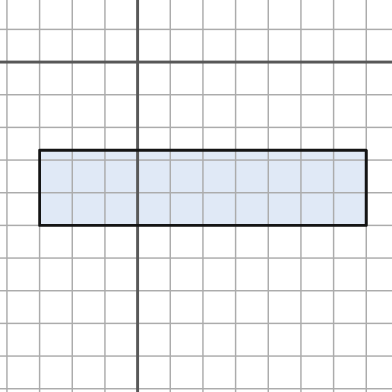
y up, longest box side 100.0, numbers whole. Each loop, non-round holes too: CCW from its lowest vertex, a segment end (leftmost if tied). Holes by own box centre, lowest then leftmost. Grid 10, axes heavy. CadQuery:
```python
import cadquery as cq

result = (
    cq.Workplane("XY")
    .moveTo(-30.0, -50.0)
    .lineTo(70.0, -50.0)
    .lineTo(70.0, -27.0)
    .lineTo(-30.0, -27.0)
    .close()
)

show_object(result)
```